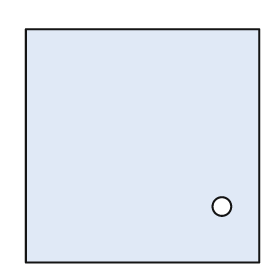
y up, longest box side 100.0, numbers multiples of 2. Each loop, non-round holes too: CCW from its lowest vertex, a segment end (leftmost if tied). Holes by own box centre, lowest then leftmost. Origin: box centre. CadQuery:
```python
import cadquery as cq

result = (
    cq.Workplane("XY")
    .moveTo(-50.0, -50.0)
    .lineTo(50.0, -50.0)
    .lineTo(50.0, 50.0)
    .lineTo(-50.0, 50.0)
    .close()
    .moveTo(34.0, -26.0)
    .circle(4.0)
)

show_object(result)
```